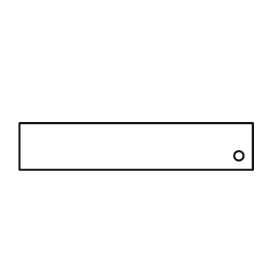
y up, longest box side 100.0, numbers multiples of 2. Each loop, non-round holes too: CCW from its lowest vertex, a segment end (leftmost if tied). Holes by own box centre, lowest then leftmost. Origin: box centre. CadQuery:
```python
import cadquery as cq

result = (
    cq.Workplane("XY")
    .moveTo(-50.0, -10.0)
    .lineTo(50.0, -10.0)
    .lineTo(50.0, 10.0)
    .lineTo(-50.0, 10.0)
    .close()
    .moveTo(44.0, -4.0)
    .circle(2.0)
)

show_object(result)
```